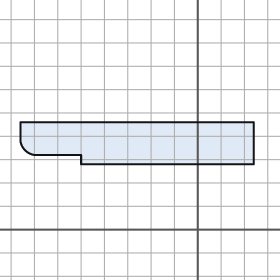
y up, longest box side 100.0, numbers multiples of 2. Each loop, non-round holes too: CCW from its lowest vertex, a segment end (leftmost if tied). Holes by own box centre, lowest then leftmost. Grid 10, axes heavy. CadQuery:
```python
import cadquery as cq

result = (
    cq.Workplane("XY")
    .moveTo(-50.0, 28.0)
    .lineTo(24.0, 28.0)
    .lineTo(24.0, 46.0)
    .lineTo(-76.0, 46.0)
    .lineTo(-76.0, 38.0)
    .threePointArc((-74.0, 34.0), (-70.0, 32.0))
    .lineTo(-50.0, 32.0)
    .close()
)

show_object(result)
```